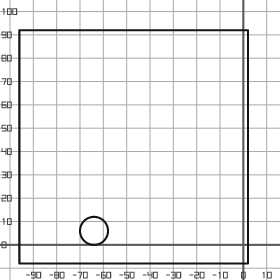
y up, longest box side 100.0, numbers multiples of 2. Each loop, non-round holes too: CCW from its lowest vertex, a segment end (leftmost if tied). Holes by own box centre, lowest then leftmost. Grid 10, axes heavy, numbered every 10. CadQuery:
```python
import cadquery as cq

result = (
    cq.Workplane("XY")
    .moveTo(-96.0, -8.0)
    .lineTo(2.0, -8.0)
    .lineTo(2.0, 92.0)
    .lineTo(-96.0, 92.0)
    .close()
    .moveTo(-64.0, 6.0)
    .circle(6.0)
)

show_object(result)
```